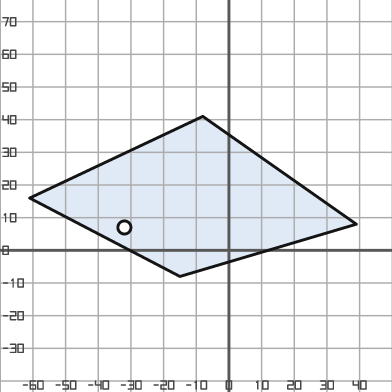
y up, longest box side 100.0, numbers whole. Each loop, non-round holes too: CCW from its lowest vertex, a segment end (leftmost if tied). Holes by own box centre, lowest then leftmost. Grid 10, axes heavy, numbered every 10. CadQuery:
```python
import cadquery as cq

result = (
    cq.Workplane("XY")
    .moveTo(-15.0, -8.0)
    .lineTo(39.0, 8.0)
    .lineTo(-8.0, 41.0)
    .lineTo(-61.0, 16.0)
    .close()
    .moveTo(-32.0, 7.0)
    .circle(2.0)
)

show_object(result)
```